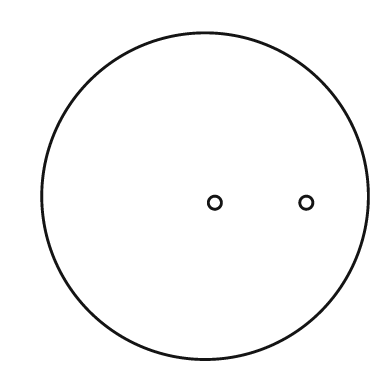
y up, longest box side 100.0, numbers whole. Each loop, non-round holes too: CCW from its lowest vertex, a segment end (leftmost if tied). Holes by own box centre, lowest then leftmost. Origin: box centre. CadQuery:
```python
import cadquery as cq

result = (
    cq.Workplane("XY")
    .moveTo(0.0, 0.0)
    .circle(50.0)
    .moveTo(3.0, -2.0)
    .circle(2.0)
    .moveTo(31.0, -2.0)
    .circle(2.0)
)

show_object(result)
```